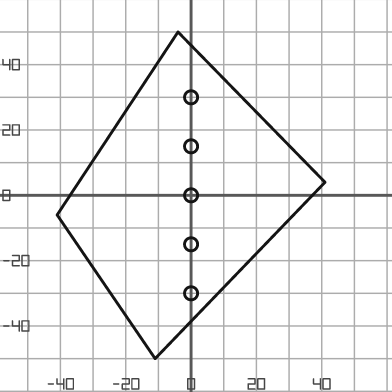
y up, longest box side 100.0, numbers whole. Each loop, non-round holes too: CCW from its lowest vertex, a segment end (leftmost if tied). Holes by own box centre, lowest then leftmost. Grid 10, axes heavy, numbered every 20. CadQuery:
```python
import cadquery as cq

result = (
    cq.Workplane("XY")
    .moveTo(-11.0, -50.0)
    .lineTo(41.0, 4.0)
    .lineTo(-4.0, 50.0)
    .lineTo(-41.0, -6.0)
    .close()
    .moveTo(0.0, -30.0)
    .circle(2.0)
    .moveTo(0.0, -15.0)
    .circle(2.0)
    .moveTo(0.0, 0.0)
    .circle(2.0)
    .moveTo(0.0, 15.0)
    .circle(2.0)
    .moveTo(0.0, 30.0)
    .circle(2.0)
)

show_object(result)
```